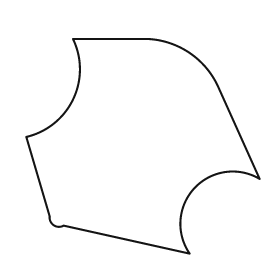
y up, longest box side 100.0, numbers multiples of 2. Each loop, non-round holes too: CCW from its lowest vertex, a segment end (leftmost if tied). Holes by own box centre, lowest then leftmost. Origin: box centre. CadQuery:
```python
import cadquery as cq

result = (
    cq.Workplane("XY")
    .moveTo(20.0, -46.0)
    .threePointArc((22.0, -18.0), (50.0, -14.0))
    .lineTo(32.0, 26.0)
    .threePointArc((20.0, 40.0), (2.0, 46.0))
    .lineTo(-30.0, 46.0)
    .threePointArc((-30.0, 20.0), (-50.0, 4.0))
    .lineTo(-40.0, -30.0)
    .threePointArc((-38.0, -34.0), (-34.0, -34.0))
    .close()
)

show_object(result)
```